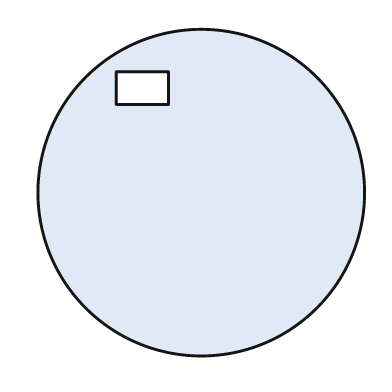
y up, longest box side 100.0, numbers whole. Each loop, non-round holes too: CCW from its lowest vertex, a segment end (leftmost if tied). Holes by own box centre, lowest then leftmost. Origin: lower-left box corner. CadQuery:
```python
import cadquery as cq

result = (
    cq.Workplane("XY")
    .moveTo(50.0, 50.0)
    .circle(50.0)
    .moveTo(24.0, 77.0)
    .lineTo(40.0, 77.0)
    .lineTo(40.0, 87.0)
    .lineTo(24.0, 87.0)
    .close()
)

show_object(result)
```